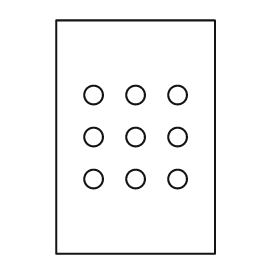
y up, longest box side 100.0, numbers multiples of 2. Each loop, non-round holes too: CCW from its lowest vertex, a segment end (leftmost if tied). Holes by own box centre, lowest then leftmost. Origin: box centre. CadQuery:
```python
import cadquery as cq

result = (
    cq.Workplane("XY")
    .moveTo(-34.0, -50.0)
    .lineTo(34.0, -50.0)
    .lineTo(34.0, 50.0)
    .lineTo(-34.0, 50.0)
    .close()
    .moveTo(-18.0, -18.0)
    .circle(4.0)
    .moveTo(0.0, -18.0)
    .circle(4.0)
    .moveTo(18.0, -18.0)
    .circle(4.0)
    .moveTo(-18.0, 0.0)
    .circle(4.0)
    .moveTo(0.0, 0.0)
    .circle(4.0)
    .moveTo(18.0, 0.0)
    .circle(4.0)
    .moveTo(-18.0, 18.0)
    .circle(4.0)
    .moveTo(0.0, 18.0)
    .circle(4.0)
    .moveTo(18.0, 18.0)
    .circle(4.0)
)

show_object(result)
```